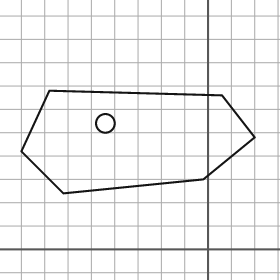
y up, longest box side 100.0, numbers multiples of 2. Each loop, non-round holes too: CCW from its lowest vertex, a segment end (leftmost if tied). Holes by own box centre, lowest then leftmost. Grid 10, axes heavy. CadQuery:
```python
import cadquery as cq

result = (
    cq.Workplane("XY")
    .moveTo(-62.0, 24.0)
    .lineTo(-2.0, 30.0)
    .lineTo(20.0, 48.0)
    .lineTo(6.0, 66.0)
    .lineTo(-68.0, 68.0)
    .lineTo(-80.0, 42.0)
    .close()
    .moveTo(-44.0, 54.0)
    .circle(4.0)
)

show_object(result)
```